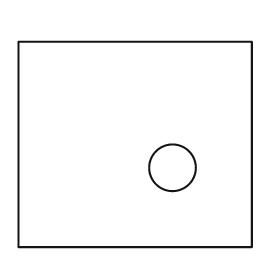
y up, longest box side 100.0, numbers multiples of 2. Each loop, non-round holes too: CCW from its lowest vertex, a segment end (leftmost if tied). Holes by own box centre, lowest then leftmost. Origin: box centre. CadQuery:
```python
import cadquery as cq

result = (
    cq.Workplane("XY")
    .moveTo(-50.0, -44.0)
    .lineTo(50.0, -44.0)
    .lineTo(50.0, 44.0)
    .lineTo(-50.0, 44.0)
    .close()
    .moveTo(16.0, -10.0)
    .circle(10.0)
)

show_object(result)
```